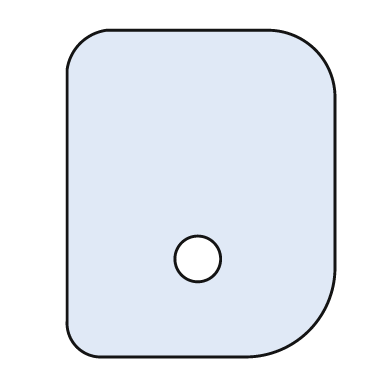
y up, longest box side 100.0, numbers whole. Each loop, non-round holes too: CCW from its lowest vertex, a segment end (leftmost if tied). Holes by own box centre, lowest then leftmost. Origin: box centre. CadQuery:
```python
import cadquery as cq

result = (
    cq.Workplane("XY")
    .moveTo(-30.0, -50.0)
    .lineTo(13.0, -50.0)
    .threePointArc((33.0, -42.0), (41.0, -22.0))
    .lineTo(41.0, 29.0)
    .threePointArc((35.0, 44.0), (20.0, 50.0))
    .lineTo(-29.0, 50.0)
    .threePointArc((-37.0, 46.0), (-41.0, 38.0))
    .lineTo(-41.0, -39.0)
    .threePointArc((-38.0, -47.0), (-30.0, -50.0))
    .close()
    .moveTo(-1.0, -20.0)
    .circle(7.0)
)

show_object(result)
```